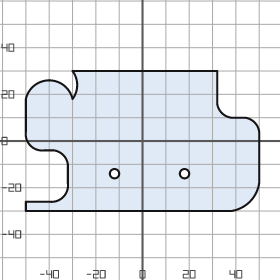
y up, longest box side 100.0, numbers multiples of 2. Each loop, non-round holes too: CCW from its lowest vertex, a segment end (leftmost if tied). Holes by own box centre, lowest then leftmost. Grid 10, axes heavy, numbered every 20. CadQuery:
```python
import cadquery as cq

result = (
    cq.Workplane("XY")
    .moveTo(-50.0, -30.0)
    .lineTo(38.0, -30.0)
    .threePointArc((46.0, -26.0), (50.0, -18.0))
    .lineTo(50.0, 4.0)
    .threePointArc((48.0, 8.0), (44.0, 10.0))
    .lineTo(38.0, 10.0)
    .threePointArc((34.0, 12.0), (32.0, 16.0))
    .lineTo(32.0, 30.0)
    .lineTo(-30.0, 30.0)
    .threePointArc((-28.0, 24.0), (-30.0, 18.0))
    .threePointArc((-40.0, 26.0), (-50.0, 18.0))
    .lineTo(-50.0, 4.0)
    .threePointArc((-48.0, -2.0), (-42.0, -4.0))
    .lineTo(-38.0, -4.0)
    .threePointArc((-34.0, -6.0), (-32.0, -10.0))
    .lineTo(-32.0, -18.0)
    .threePointArc((-34.0, -24.0), (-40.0, -26.0))
    .lineTo(-50.0, -26.0)
    .close()
    .moveTo(-12.0, -14.0)
    .circle(2.0)
    .moveTo(18.0, -14.0)
    .circle(2.0)
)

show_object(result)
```